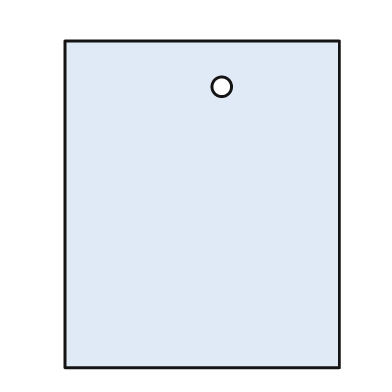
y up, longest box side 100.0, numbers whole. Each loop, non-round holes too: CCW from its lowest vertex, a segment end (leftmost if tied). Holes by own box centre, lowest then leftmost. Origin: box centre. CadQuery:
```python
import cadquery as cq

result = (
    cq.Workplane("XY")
    .moveTo(-42.0, -50.0)
    .lineTo(42.0, -50.0)
    .lineTo(42.0, 50.0)
    .lineTo(-42.0, 50.0)
    .close()
    .moveTo(6.0, 36.0)
    .circle(3.0)
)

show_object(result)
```